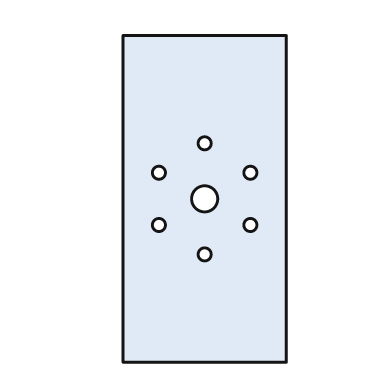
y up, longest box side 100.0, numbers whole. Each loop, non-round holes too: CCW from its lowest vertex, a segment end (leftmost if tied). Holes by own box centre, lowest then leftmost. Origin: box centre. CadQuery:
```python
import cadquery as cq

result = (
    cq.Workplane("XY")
    .moveTo(-25.0, -50.0)
    .lineTo(25.0, -50.0)
    .lineTo(25.0, 50.0)
    .lineTo(-25.0, 50.0)
    .close()
    .moveTo(0.0, -17.0)
    .circle(2.0)
    .moveTo(-14.0, -8.0)
    .circle(2.0)
    .moveTo(14.0, -8.0)
    .circle(2.0)
    .moveTo(0.0, 0.0)
    .circle(4.0)
    .moveTo(-14.0, 8.0)
    .circle(2.0)
    .moveTo(14.0, 8.0)
    .circle(2.0)
    .moveTo(0.0, 17.0)
    .circle(2.0)
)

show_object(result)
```